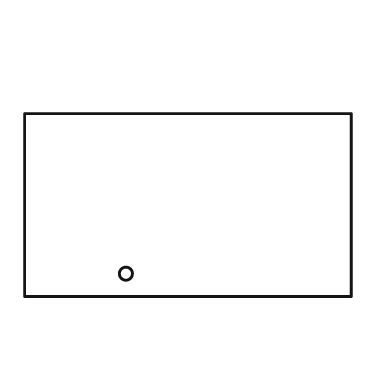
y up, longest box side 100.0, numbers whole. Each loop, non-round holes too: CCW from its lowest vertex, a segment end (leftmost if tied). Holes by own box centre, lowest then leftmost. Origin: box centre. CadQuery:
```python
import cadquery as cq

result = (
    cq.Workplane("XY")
    .moveTo(-50.0, -28.0)
    .lineTo(50.0, -28.0)
    .lineTo(50.0, 28.0)
    .lineTo(-50.0, 28.0)
    .close()
    .moveTo(-19.0, -21.0)
    .circle(2.0)
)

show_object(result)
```